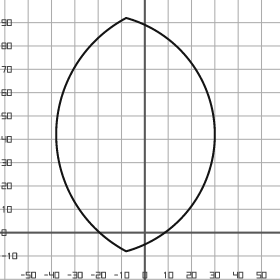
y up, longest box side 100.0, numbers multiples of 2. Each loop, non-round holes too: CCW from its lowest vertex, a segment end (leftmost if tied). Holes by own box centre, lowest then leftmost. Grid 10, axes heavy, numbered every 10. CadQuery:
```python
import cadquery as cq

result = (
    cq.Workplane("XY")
    .moveTo(-8.0, -8.0)
    .threePointArc((30.0, 42.0), (-8.0, 92.0))
    .threePointArc((-38.0, 42.0), (-8.0, -8.0))
    .close()
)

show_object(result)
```